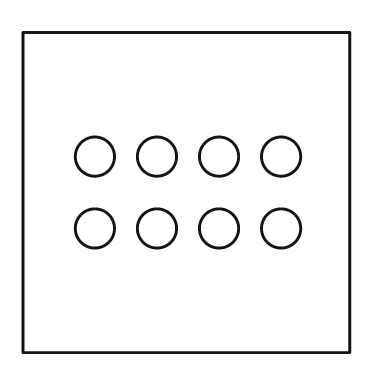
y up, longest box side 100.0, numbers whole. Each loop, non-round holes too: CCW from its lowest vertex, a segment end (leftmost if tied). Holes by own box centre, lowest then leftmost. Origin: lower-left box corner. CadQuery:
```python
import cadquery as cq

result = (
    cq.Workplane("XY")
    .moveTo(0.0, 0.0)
    .lineTo(100.0, 0.0)
    .lineTo(100.0, 98.0)
    .lineTo(0.0, 98.0)
    .close()
    .moveTo(22.0, 38.0)
    .circle(6.0)
    .moveTo(41.0, 38.0)
    .circle(6.0)
    .moveTo(60.0, 38.0)
    .circle(6.0)
    .moveTo(79.0, 38.0)
    .circle(6.0)
    .moveTo(22.0, 60.0)
    .circle(6.0)
    .moveTo(41.0, 60.0)
    .circle(6.0)
    .moveTo(60.0, 60.0)
    .circle(6.0)
    .moveTo(79.0, 60.0)
    .circle(6.0)
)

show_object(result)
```